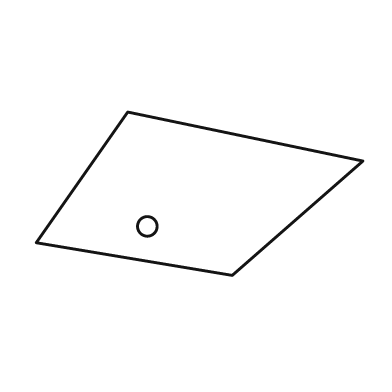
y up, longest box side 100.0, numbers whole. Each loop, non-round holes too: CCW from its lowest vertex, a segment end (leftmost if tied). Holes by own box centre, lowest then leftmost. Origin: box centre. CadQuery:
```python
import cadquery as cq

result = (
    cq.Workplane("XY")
    .moveTo(10.0, -25.0)
    .lineTo(50.0, 10.0)
    .lineTo(-22.0, 25.0)
    .lineTo(-50.0, -15.0)
    .close()
    .moveTo(-16.0, -10.0)
    .circle(3.0)
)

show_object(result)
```